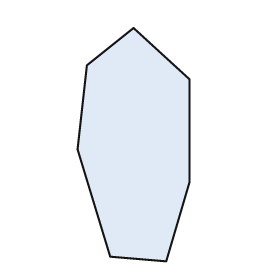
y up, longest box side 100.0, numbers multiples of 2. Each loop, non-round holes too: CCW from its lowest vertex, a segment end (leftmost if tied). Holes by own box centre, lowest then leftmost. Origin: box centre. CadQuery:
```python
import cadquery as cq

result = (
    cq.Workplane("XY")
    .moveTo(14.0, -50.0)
    .lineTo(24.0, -16.0)
    .lineTo(24.0, 28.0)
    .lineTo(0.0, 50.0)
    .lineTo(-20.0, 34.0)
    .lineTo(-24.0, -2.0)
    .lineTo(-10.0, -48.0)
    .close()
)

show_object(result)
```